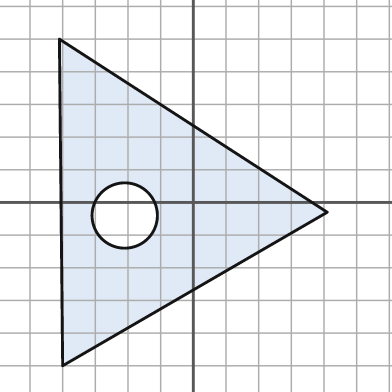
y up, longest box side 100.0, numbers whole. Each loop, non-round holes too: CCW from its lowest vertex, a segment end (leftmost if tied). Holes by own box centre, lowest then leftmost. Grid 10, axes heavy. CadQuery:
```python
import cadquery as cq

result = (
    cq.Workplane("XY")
    .moveTo(-40.0, -50.0)
    .lineTo(41.0, -3.0)
    .lineTo(-41.0, 50.0)
    .close()
    .moveTo(-21.0, -4.0)
    .circle(10.0)
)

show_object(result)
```